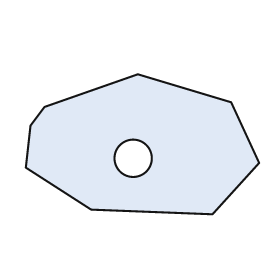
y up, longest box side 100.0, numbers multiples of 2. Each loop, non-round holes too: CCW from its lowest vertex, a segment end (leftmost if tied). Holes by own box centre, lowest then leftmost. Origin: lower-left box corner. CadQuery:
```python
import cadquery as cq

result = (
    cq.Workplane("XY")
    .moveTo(80.0, 0.0)
    .lineTo(100.0, 22.0)
    .lineTo(88.0, 48.0)
    .lineTo(48.0, 60.0)
    .lineTo(8.0, 46.0)
    .lineTo(2.0, 38.0)
    .lineTo(0.0, 20.0)
    .lineTo(28.0, 2.0)
    .close()
    .moveTo(46.0, 24.0)
    .circle(8.0)
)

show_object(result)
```